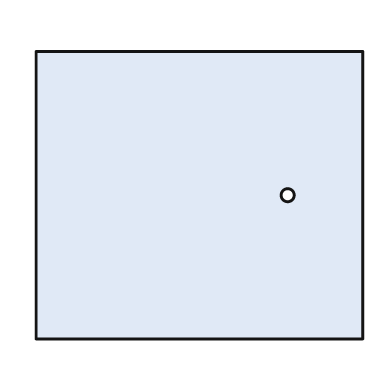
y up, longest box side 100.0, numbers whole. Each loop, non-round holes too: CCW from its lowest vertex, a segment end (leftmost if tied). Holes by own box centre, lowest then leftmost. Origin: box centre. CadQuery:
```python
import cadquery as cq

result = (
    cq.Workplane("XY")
    .moveTo(-50.0, -44.0)
    .lineTo(50.0, -44.0)
    .lineTo(50.0, 44.0)
    .lineTo(-50.0, 44.0)
    .close()
    .moveTo(27.0, 0.0)
    .circle(2.0)
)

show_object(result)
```